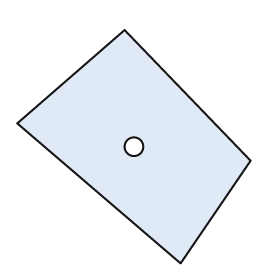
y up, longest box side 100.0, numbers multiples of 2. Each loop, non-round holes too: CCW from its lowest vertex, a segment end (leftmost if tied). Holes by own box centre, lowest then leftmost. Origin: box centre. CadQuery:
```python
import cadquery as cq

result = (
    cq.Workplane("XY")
    .moveTo(20.0, -50.0)
    .lineTo(50.0, -6.0)
    .lineTo(-4.0, 50.0)
    .lineTo(-50.0, 10.0)
    .close()
    .moveTo(0.0, 0.0)
    .circle(4.0)
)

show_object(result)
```